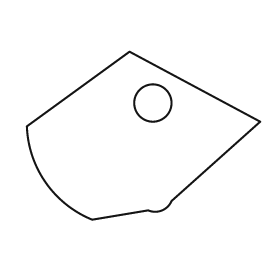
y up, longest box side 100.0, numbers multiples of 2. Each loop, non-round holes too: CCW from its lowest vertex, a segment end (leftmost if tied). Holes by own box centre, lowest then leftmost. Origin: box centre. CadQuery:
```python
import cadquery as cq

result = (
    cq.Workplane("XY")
    .moveTo(-22.0, -36.0)
    .lineTo(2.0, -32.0)
    .threePointArc((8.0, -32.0), (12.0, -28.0))
    .lineTo(50.0, 6.0)
    .lineTo(-6.0, 36.0)
    .lineTo(-50.0, 4.0)
    .threePointArc((-42.0, -20.0), (-22.0, -36.0))
    .close()
    .moveTo(4.0, 14.0)
    .circle(8.0)
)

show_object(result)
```